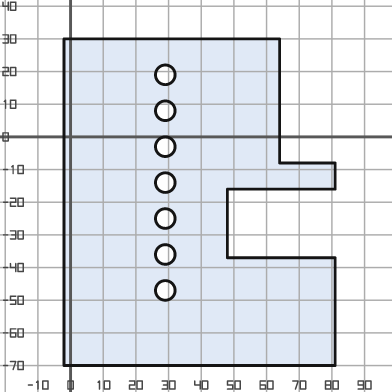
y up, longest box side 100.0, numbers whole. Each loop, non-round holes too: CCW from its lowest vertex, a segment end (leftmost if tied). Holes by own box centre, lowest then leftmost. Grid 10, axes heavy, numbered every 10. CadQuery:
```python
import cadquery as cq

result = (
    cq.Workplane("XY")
    .moveTo(-2.0, -70.0)
    .lineTo(81.0, -70.0)
    .lineTo(81.0, -37.0)
    .lineTo(48.0, -37.0)
    .lineTo(48.0, -16.0)
    .lineTo(81.0, -16.0)
    .lineTo(81.0, -8.0)
    .lineTo(64.0, -8.0)
    .lineTo(64.0, 30.0)
    .lineTo(-2.0, 30.0)
    .close()
    .moveTo(29.0, -47.0)
    .circle(3.0)
    .moveTo(29.0, -36.0)
    .circle(3.0)
    .moveTo(29.0, -25.0)
    .circle(3.0)
    .moveTo(29.0, -14.0)
    .circle(3.0)
    .moveTo(29.0, -3.0)
    .circle(3.0)
    .moveTo(29.0, 8.0)
    .circle(3.0)
    .moveTo(29.0, 19.0)
    .circle(3.0)
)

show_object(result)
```